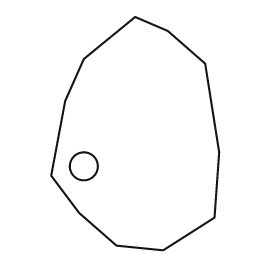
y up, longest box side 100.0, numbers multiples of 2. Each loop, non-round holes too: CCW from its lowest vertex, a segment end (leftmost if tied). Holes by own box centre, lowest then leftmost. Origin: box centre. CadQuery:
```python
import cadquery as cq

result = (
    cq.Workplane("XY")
    .moveTo(12.0, -50.0)
    .lineTo(34.0, -36.0)
    .lineTo(36.0, -8.0)
    .lineTo(30.0, 30.0)
    .lineTo(14.0, 44.0)
    .lineTo(0.0, 50.0)
    .lineTo(-22.0, 32.0)
    .lineTo(-30.0, 14.0)
    .lineTo(-36.0, -18.0)
    .lineTo(-24.0, -34.0)
    .lineTo(-8.0, -48.0)
    .close()
    .moveTo(-22.0, -14.0)
    .circle(6.0)
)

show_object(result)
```